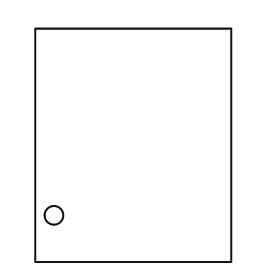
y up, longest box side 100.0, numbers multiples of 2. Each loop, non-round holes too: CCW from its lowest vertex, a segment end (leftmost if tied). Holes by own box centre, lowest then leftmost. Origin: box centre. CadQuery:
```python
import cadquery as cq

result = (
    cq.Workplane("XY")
    .moveTo(-42.0, -50.0)
    .lineTo(42.0, -50.0)
    .lineTo(42.0, 50.0)
    .lineTo(-42.0, 50.0)
    .close()
    .moveTo(-34.0, -30.0)
    .circle(4.0)
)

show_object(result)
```